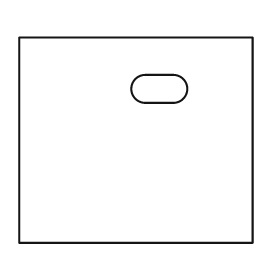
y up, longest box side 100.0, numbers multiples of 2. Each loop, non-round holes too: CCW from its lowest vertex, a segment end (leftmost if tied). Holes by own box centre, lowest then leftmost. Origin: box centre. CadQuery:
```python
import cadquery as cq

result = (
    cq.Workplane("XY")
    .moveTo(-50.0, -44.0)
    .lineTo(50.0, -44.0)
    .lineTo(50.0, 44.0)
    .lineTo(-50.0, 44.0)
    .close()
    .moveTo(4.0, 16.0)
    .lineTo(16.0, 16.0)
    .threePointArc((22.0, 22.0), (16.0, 28.0))
    .lineTo(4.0, 28.0)
    .threePointArc((-2.0, 22.0), (4.0, 16.0))
    .close()
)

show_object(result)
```